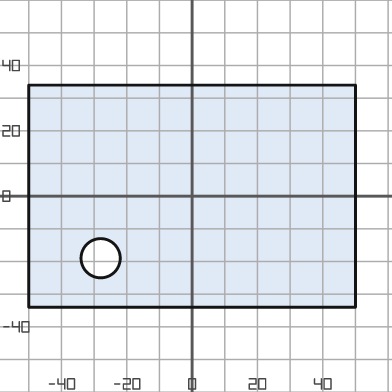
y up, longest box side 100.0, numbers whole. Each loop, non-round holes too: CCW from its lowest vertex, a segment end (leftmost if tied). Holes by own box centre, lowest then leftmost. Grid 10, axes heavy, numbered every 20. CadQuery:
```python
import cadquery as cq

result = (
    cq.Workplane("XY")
    .moveTo(-50.0, -34.0)
    .lineTo(50.0, -34.0)
    .lineTo(50.0, 34.0)
    .lineTo(-50.0, 34.0)
    .close()
    .moveTo(-28.0, -19.0)
    .circle(6.0)
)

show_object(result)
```